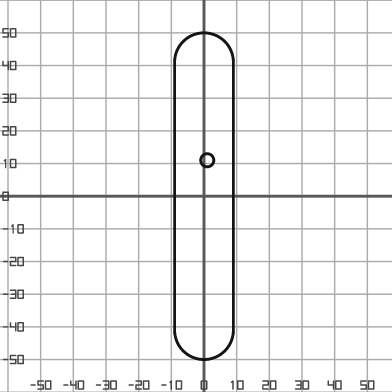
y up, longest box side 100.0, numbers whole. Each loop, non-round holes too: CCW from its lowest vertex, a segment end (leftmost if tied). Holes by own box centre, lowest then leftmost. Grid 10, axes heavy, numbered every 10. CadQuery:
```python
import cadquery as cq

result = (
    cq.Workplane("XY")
    .moveTo(-9.0, -41.0)
    .threePointArc((0.0, -50.0), (9.0, -41.0))
    .lineTo(9.0, 41.0)
    .threePointArc((0.0, 50.0), (-9.0, 41.0))
    .close()
    .moveTo(1.0, 11.0)
    .circle(2.0)
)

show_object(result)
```